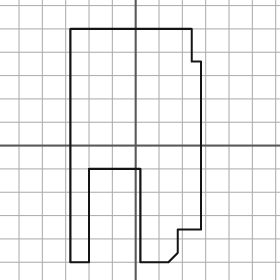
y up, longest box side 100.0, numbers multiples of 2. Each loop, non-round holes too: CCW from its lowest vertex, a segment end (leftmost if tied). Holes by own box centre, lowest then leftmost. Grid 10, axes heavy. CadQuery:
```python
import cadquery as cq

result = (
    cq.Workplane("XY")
    .moveTo(-28.0, -50.0)
    .lineTo(-20.0, -50.0)
    .lineTo(-20.0, -10.0)
    .lineTo(2.0, -10.0)
    .lineTo(2.0, -50.0)
    .lineTo(14.0, -50.0)
    .lineTo(18.0, -46.0)
    .lineTo(18.0, -36.0)
    .lineTo(28.0, -36.0)
    .lineTo(28.0, 36.0)
    .lineTo(24.0, 36.0)
    .lineTo(24.0, 50.0)
    .lineTo(-28.0, 50.0)
    .close()
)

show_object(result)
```